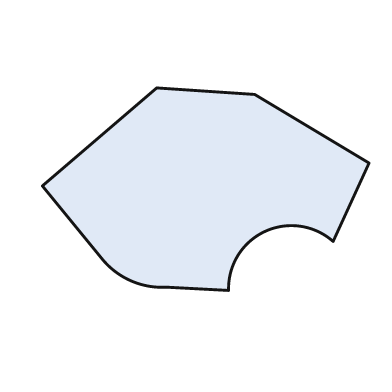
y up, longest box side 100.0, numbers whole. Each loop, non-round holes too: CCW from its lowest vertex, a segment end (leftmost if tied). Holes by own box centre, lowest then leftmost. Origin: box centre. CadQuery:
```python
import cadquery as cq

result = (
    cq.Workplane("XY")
    .moveTo(7.0, -31.0)
    .threePointArc((18.0, -13.0), (39.0, -16.0))
    .lineTo(50.0, 8.0)
    .lineTo(15.0, 29.0)
    .lineTo(-15.0, 31.0)
    .lineTo(-50.0, 1.0)
    .lineTo(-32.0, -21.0)
    .threePointArc((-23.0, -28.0), (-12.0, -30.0))
    .close()
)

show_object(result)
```